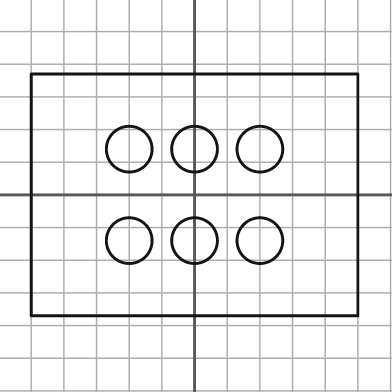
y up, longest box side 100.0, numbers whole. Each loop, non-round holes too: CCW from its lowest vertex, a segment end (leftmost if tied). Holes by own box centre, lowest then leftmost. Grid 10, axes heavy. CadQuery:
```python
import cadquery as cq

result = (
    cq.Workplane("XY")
    .moveTo(-50.0, -37.0)
    .lineTo(50.0, -37.0)
    .lineTo(50.0, 37.0)
    .lineTo(-50.0, 37.0)
    .close()
    .moveTo(-20.0, -14.0)
    .circle(7.0)
    .moveTo(0.0, -14.0)
    .circle(7.0)
    .moveTo(20.0, -14.0)
    .circle(7.0)
    .moveTo(-20.0, 14.0)
    .circle(7.0)
    .moveTo(0.0, 14.0)
    .circle(7.0)
    .moveTo(20.0, 14.0)
    .circle(7.0)
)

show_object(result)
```